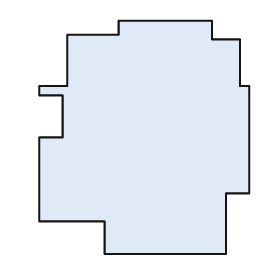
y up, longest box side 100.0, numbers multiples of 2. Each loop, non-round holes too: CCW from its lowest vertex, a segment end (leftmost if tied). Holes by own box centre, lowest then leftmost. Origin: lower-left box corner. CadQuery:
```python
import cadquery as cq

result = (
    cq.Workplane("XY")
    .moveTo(28.0, 0.0)
    .lineTo(80.0, 0.0)
    .lineTo(80.0, 26.0)
    .lineTo(90.0, 26.0)
    .lineTo(90.0, 72.0)
    .lineTo(86.0, 72.0)
    .lineTo(86.0, 92.0)
    .lineTo(74.0, 92.0)
    .lineTo(74.0, 100.0)
    .lineTo(34.0, 100.0)
    .lineTo(34.0, 94.0)
    .lineTo(12.0, 94.0)
    .lineTo(12.0, 72.0)
    .lineTo(0.0, 72.0)
    .lineTo(0.0, 68.0)
    .lineTo(10.0, 68.0)
    .lineTo(10.0, 50.0)
    .lineTo(0.0, 50.0)
    .lineTo(0.0, 14.0)
    .lineTo(28.0, 14.0)
    .close()
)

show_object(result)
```